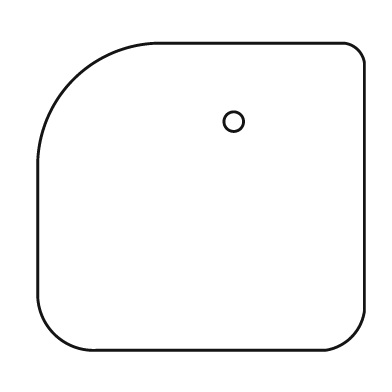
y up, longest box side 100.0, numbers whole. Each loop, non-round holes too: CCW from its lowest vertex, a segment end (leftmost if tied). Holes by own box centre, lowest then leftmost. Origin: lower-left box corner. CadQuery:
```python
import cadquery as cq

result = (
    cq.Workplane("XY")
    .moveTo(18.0, 0.0)
    .lineTo(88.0, 0.0)
    .threePointArc((96.0, 4.0), (100.0, 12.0))
    .lineTo(100.0, 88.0)
    .threePointArc((98.0, 92.0), (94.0, 94.0))
    .lineTo(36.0, 94.0)
    .threePointArc((11.0, 83.0), (0.0, 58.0))
    .lineTo(0.0, 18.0)
    .threePointArc((5.0, 5.0), (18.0, 0.0))
    .close()
    .moveTo(60.0, 70.0)
    .circle(3.0)
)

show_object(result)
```